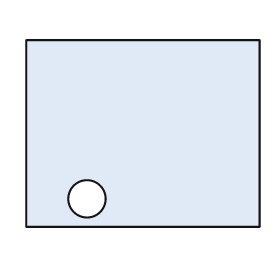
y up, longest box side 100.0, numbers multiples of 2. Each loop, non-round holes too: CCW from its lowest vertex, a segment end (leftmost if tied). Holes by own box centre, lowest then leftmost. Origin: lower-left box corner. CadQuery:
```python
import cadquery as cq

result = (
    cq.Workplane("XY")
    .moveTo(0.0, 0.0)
    .lineTo(100.0, 0.0)
    .lineTo(100.0, 80.0)
    .lineTo(0.0, 80.0)
    .close()
    .moveTo(26.0, 12.0)
    .circle(8.0)
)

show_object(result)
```